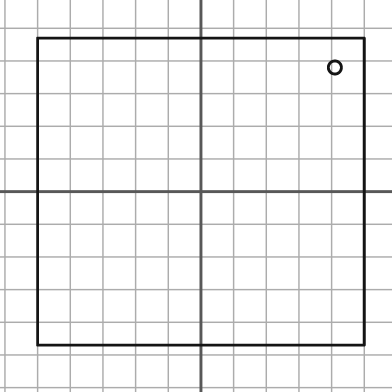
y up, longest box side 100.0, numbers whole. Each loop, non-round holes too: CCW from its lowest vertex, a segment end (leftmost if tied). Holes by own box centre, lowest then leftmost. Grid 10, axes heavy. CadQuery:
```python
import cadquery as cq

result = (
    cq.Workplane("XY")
    .moveTo(-50.0, -47.0)
    .lineTo(50.0, -47.0)
    .lineTo(50.0, 47.0)
    .lineTo(-50.0, 47.0)
    .close()
    .moveTo(41.0, 38.0)
    .circle(2.0)
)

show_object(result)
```